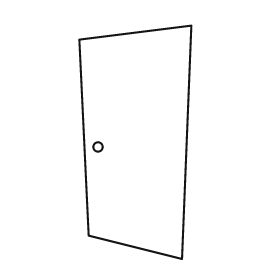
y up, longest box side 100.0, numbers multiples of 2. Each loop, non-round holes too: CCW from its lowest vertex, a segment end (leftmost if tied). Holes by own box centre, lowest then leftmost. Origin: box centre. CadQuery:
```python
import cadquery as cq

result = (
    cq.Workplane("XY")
    .moveTo(20.0, -50.0)
    .lineTo(24.0, 50.0)
    .lineTo(-24.0, 44.0)
    .lineTo(-20.0, -40.0)
    .close()
    .moveTo(-16.0, -2.0)
    .circle(2.0)
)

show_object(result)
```